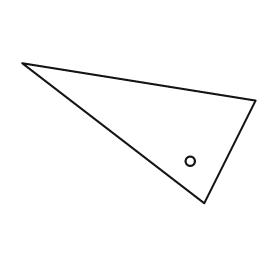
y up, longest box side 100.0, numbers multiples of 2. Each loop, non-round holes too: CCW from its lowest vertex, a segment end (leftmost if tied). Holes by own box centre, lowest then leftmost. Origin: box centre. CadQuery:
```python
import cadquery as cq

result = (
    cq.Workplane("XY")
    .moveTo(28.0, -30.0)
    .lineTo(50.0, 14.0)
    .lineTo(-50.0, 30.0)
    .close()
    .moveTo(22.0, -12.0)
    .circle(2.0)
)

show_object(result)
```